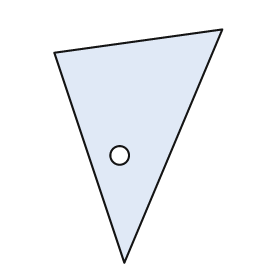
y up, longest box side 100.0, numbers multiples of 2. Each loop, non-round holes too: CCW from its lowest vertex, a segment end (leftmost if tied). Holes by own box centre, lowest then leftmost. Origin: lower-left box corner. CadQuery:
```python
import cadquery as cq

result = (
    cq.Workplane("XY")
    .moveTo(30.0, 0.0)
    .lineTo(72.0, 100.0)
    .lineTo(0.0, 90.0)
    .close()
    .moveTo(28.0, 46.0)
    .circle(4.0)
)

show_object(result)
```